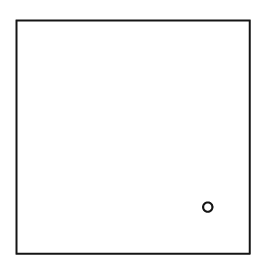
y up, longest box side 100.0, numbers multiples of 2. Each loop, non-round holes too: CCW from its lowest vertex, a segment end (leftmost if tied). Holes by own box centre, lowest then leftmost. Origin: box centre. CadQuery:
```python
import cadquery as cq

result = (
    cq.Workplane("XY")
    .moveTo(-50.0, -50.0)
    .lineTo(50.0, -50.0)
    .lineTo(50.0, 50.0)
    .lineTo(-50.0, 50.0)
    .close()
    .moveTo(32.0, -30.0)
    .circle(2.0)
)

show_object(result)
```